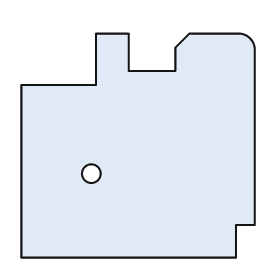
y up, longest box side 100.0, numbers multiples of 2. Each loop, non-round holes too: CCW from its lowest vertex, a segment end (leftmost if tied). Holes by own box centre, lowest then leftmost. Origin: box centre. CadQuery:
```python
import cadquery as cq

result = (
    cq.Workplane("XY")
    .moveTo(-50.0, -48.0)
    .lineTo(42.0, -48.0)
    .lineTo(42.0, -34.0)
    .lineTo(50.0, -34.0)
    .lineTo(50.0, 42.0)
    .threePointArc((48.0, 46.0), (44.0, 48.0))
    .lineTo(22.0, 48.0)
    .lineTo(16.0, 42.0)
    .lineTo(16.0, 32.0)
    .lineTo(-4.0, 32.0)
    .lineTo(-4.0, 48.0)
    .lineTo(-18.0, 48.0)
    .lineTo(-18.0, 26.0)
    .lineTo(-50.0, 26.0)
    .close()
    .moveTo(-20.0, -12.0)
    .circle(4.0)
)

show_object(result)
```